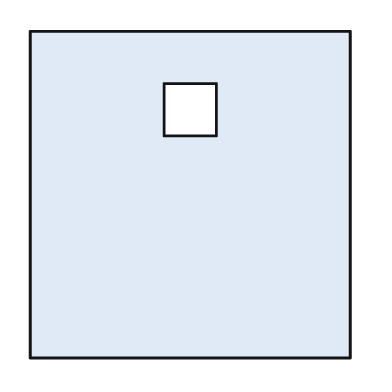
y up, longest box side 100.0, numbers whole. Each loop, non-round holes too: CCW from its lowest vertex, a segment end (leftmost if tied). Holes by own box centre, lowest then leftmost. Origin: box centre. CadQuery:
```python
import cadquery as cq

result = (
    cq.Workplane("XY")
    .moveTo(-49.0, -50.0)
    .lineTo(49.0, -50.0)
    .lineTo(49.0, 50.0)
    .lineTo(-49.0, 50.0)
    .close()
    .moveTo(-8.0, 18.0)
    .lineTo(8.0, 18.0)
    .lineTo(8.0, 34.0)
    .lineTo(-8.0, 34.0)
    .close()
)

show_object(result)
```